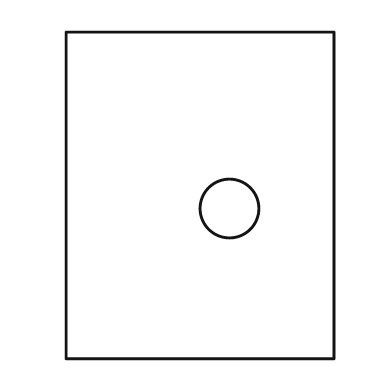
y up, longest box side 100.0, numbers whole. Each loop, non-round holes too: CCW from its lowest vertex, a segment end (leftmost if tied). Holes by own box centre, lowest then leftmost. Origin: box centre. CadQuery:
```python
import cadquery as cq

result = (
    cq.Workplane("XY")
    .moveTo(-41.0, -50.0)
    .lineTo(41.0, -50.0)
    .lineTo(41.0, 50.0)
    .lineTo(-41.0, 50.0)
    .close()
    .moveTo(9.0, -4.0)
    .circle(9.0)
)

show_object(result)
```